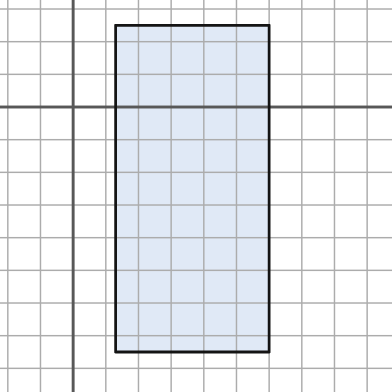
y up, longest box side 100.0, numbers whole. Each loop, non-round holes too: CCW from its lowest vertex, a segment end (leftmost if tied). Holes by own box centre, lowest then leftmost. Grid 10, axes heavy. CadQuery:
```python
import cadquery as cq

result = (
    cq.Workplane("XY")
    .moveTo(13.0, -75.0)
    .lineTo(60.0, -75.0)
    .lineTo(60.0, 25.0)
    .lineTo(13.0, 25.0)
    .close()
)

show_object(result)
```